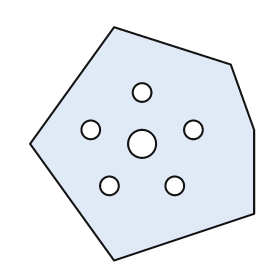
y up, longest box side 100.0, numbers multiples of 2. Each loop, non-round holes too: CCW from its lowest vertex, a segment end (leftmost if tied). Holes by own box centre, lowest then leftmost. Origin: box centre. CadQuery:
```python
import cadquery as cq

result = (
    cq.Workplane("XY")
    .moveTo(-12.0, -50.0)
    .lineTo(48.0, -30.0)
    .lineTo(48.0, 6.0)
    .lineTo(38.0, 34.0)
    .lineTo(-12.0, 50.0)
    .lineTo(-48.0, 0.0)
    .close()
    .moveTo(-14.0, -18.0)
    .circle(4.0)
    .moveTo(14.0, -18.0)
    .circle(4.0)
    .moveTo(0.0, 0.0)
    .circle(6.0)
    .moveTo(-22.0, 6.0)
    .circle(4.0)
    .moveTo(22.0, 6.0)
    .circle(4.0)
    .moveTo(0.0, 22.0)
    .circle(4.0)
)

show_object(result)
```